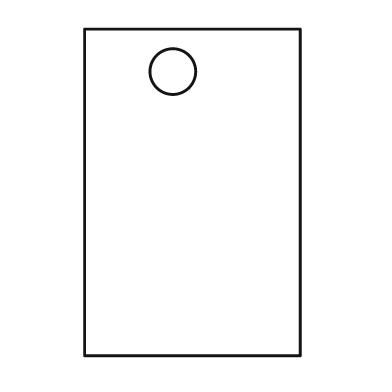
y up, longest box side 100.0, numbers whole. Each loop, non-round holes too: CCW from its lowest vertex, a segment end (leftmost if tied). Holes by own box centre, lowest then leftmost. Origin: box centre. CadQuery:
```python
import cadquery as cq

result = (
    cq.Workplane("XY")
    .moveTo(-33.0, -50.0)
    .lineTo(33.0, -50.0)
    .lineTo(33.0, 50.0)
    .lineTo(-33.0, 50.0)
    .close()
    .moveTo(-6.0, 37.0)
    .circle(7.0)
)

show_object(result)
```